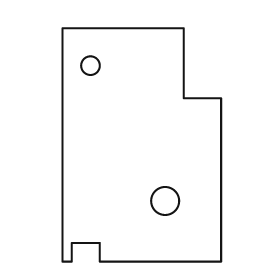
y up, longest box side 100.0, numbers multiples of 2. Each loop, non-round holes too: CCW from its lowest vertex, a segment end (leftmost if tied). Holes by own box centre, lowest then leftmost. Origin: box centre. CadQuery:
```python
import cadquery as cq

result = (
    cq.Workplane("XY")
    .moveTo(-34.0, -50.0)
    .lineTo(-30.0, -50.0)
    .lineTo(-30.0, -42.0)
    .lineTo(-18.0, -42.0)
    .lineTo(-18.0, -50.0)
    .lineTo(34.0, -50.0)
    .lineTo(34.0, 20.0)
    .lineTo(18.0, 20.0)
    .lineTo(18.0, 50.0)
    .lineTo(-34.0, 50.0)
    .close()
    .moveTo(10.0, -24.0)
    .circle(6.0)
    .moveTo(-22.0, 34.0)
    .circle(4.0)
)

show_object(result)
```